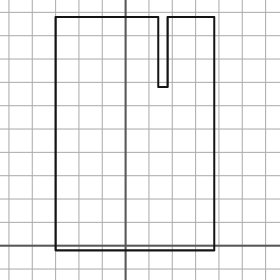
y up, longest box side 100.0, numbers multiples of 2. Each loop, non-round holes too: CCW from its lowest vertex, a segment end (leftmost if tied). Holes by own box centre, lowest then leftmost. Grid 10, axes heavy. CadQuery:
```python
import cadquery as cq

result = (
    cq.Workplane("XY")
    .moveTo(-30.0, -2.0)
    .lineTo(38.0, -2.0)
    .lineTo(38.0, 98.0)
    .lineTo(18.0, 98.0)
    .lineTo(18.0, 68.0)
    .lineTo(14.0, 68.0)
    .lineTo(14.0, 98.0)
    .lineTo(-30.0, 98.0)
    .close()
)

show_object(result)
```